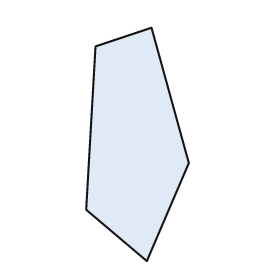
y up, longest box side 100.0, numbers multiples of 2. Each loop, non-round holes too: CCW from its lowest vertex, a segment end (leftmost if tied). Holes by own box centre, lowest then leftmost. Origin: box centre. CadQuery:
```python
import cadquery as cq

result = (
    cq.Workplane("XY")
    .moveTo(4.0, -50.0)
    .lineTo(22.0, -8.0)
    .lineTo(6.0, 50.0)
    .lineTo(-18.0, 42.0)
    .lineTo(-22.0, -28.0)
    .close()
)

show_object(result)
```